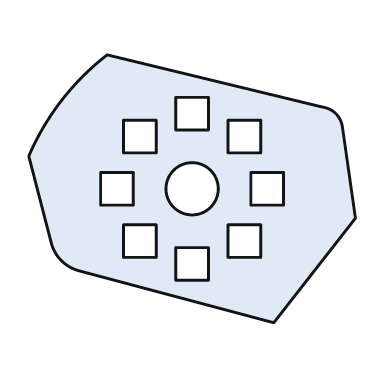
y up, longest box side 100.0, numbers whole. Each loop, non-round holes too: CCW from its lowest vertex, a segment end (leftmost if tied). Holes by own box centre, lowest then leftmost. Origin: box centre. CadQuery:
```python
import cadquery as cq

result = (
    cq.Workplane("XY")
    .moveTo(25.0, -41.0)
    .lineTo(50.0, -9.0)
    .lineTo(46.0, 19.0)
    .threePointArc((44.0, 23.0), (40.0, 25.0))
    .lineTo(-26.0, 41.0)
    .threePointArc((-40.0, 27.0), (-50.0, 10.0))
    .lineTo(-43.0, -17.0)
    .threePointArc((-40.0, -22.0), (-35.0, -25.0))
    .close()
    .moveTo(-5.0, -28.0)
    .lineTo(5.0, -28.0)
    .lineTo(5.0, -18.0)
    .lineTo(-5.0, -18.0)
    .close()
    .moveTo(-21.0, -21.0)
    .lineTo(-11.0, -21.0)
    .lineTo(-11.0, -11.0)
    .lineTo(-21.0, -11.0)
    .close()
    .moveTo(11.0, -21.0)
    .lineTo(21.0, -21.0)
    .lineTo(21.0, -11.0)
    .lineTo(11.0, -11.0)
    .close()
    .moveTo(-28.0, -5.0)
    .lineTo(-18.0, -5.0)
    .lineTo(-18.0, 5.0)
    .lineTo(-28.0, 5.0)
    .close()
    .moveTo(0.0, 0.0)
    .circle(8.0)
    .moveTo(18.0, -5.0)
    .lineTo(28.0, -5.0)
    .lineTo(28.0, 5.0)
    .lineTo(18.0, 5.0)
    .close()
    .moveTo(-21.0, 11.0)
    .lineTo(-11.0, 11.0)
    .lineTo(-11.0, 21.0)
    .lineTo(-21.0, 21.0)
    .close()
    .moveTo(11.0, 11.0)
    .lineTo(21.0, 11.0)
    .lineTo(21.0, 21.0)
    .lineTo(11.0, 21.0)
    .close()
    .moveTo(-5.0, 18.0)
    .lineTo(5.0, 18.0)
    .lineTo(5.0, 28.0)
    .lineTo(-5.0, 28.0)
    .close()
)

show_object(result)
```